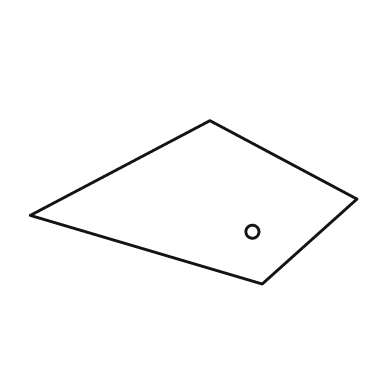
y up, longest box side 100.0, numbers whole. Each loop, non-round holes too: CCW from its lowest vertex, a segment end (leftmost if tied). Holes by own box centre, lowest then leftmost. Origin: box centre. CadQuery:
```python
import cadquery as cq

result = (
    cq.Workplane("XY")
    .moveTo(21.0, -25.0)
    .lineTo(50.0, 1.0)
    .lineTo(5.0, 25.0)
    .lineTo(-50.0, -4.0)
    .close()
    .moveTo(18.0, -9.0)
    .circle(2.0)
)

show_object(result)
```